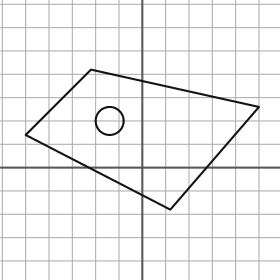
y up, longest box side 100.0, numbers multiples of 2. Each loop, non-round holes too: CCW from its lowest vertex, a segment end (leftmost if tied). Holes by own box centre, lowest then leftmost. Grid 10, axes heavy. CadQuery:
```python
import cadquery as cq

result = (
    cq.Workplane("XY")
    .moveTo(12.0, -18.0)
    .lineTo(50.0, 26.0)
    .lineTo(-22.0, 42.0)
    .lineTo(-50.0, 14.0)
    .close()
    .moveTo(-14.0, 20.0)
    .circle(6.0)
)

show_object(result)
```